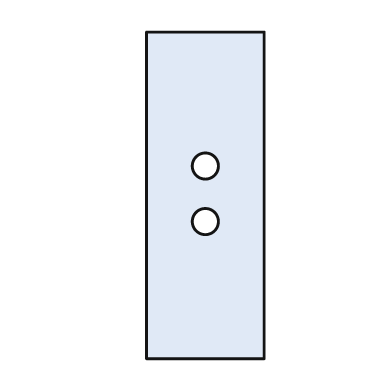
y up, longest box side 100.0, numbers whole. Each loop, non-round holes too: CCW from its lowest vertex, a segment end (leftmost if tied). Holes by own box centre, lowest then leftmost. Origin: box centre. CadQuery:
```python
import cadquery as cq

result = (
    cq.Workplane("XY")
    .moveTo(-18.0, -50.0)
    .lineTo(18.0, -50.0)
    .lineTo(18.0, 50.0)
    .lineTo(-18.0, 50.0)
    .close()
    .moveTo(0.0, -8.0)
    .circle(4.0)
    .moveTo(0.0, 9.0)
    .circle(4.0)
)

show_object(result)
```